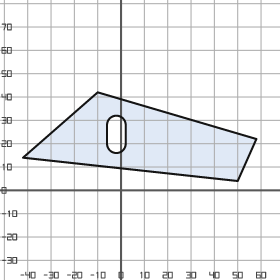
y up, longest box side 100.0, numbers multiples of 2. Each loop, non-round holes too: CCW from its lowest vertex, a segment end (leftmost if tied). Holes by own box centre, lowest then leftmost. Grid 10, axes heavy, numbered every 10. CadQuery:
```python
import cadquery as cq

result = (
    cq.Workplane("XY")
    .moveTo(50.0, 4.0)
    .lineTo(58.0, 22.0)
    .lineTo(-10.0, 42.0)
    .lineTo(-42.0, 14.0)
    .close()
    .moveTo(-6.0, 20.0)
    .threePointArc((-2.0, 16.0), (2.0, 20.0))
    .lineTo(2.0, 28.0)
    .threePointArc((-2.0, 32.0), (-6.0, 28.0))
    .close()
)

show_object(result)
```